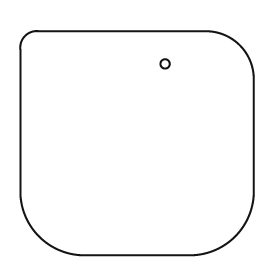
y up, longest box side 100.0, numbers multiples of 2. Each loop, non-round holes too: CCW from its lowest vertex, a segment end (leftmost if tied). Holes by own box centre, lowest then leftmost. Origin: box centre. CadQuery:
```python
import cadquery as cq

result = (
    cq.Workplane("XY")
    .moveTo(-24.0, -48.0)
    .lineTo(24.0, -48.0)
    .threePointArc((42.0, -40.0), (50.0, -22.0))
    .lineTo(50.0, 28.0)
    .threePointArc((44.0, 42.0), (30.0, 48.0))
    .lineTo(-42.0, 48.0)
    .threePointArc((-48.0, 46.0), (-50.0, 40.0))
    .lineTo(-50.0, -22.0)
    .threePointArc((-42.0, -40.0), (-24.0, -48.0))
    .close()
    .moveTo(12.0, 34.0)
    .circle(2.0)
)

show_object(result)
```